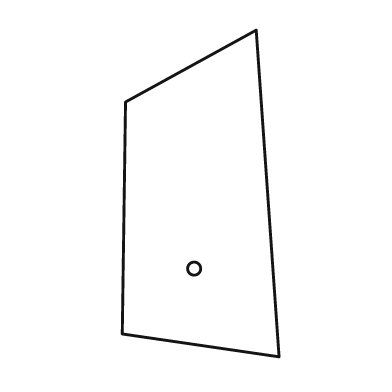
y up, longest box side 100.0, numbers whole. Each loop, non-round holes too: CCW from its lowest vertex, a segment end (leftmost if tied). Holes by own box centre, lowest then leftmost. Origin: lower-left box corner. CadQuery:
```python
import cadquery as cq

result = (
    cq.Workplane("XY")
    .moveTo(48.0, 0.0)
    .lineTo(41.0, 100.0)
    .lineTo(1.0, 78.0)
    .lineTo(0.0, 7.0)
    .close()
    .moveTo(22.0, 27.0)
    .circle(2.0)
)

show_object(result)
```